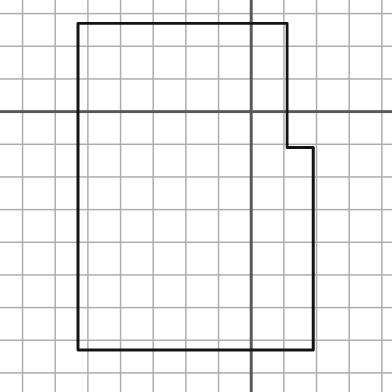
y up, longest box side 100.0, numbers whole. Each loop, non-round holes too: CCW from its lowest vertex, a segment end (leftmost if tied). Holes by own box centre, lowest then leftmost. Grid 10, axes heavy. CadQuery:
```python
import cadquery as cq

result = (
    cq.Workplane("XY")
    .moveTo(-53.0, -73.0)
    .lineTo(19.0, -73.0)
    .lineTo(19.0, -11.0)
    .lineTo(11.0, -11.0)
    .lineTo(11.0, 27.0)
    .lineTo(-53.0, 27.0)
    .close()
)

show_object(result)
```